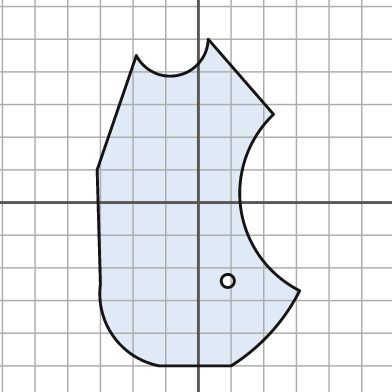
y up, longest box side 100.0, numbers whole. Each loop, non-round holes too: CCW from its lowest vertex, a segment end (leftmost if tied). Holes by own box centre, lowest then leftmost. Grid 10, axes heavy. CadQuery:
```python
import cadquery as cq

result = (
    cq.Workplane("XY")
    .moveTo(-12.0, -50.0)
    .lineTo(10.0, -50.0)
    .threePointArc((22.0, -40.0), (31.0, -27.0))
    .threePointArc((13.0, -2.0), (23.0, 27.0))
    .lineTo(3.0, 50.0)
    .threePointArc((-6.0, 39.0), (-19.0, 45.0))
    .lineTo(-31.0, 10.0)
    .lineTo(-30.0, -25.0)
    .threePointArc((-26.0, -41.0), (-12.0, -50.0))
    .close()
    .moveTo(9.0, -24.0)
    .circle(2.0)
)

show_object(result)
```